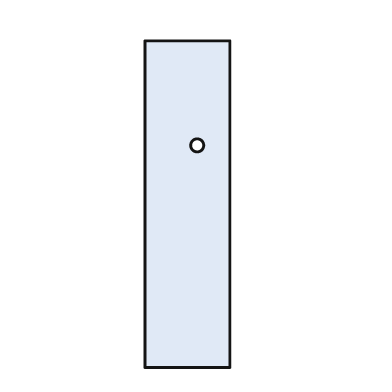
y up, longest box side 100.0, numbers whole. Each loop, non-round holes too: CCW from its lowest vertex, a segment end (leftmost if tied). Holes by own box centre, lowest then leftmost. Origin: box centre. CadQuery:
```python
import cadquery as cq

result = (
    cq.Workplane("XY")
    .moveTo(-13.0, -50.0)
    .lineTo(13.0, -50.0)
    .lineTo(13.0, 50.0)
    .lineTo(-13.0, 50.0)
    .close()
    .moveTo(3.0, 18.0)
    .circle(2.0)
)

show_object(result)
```